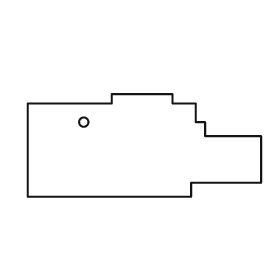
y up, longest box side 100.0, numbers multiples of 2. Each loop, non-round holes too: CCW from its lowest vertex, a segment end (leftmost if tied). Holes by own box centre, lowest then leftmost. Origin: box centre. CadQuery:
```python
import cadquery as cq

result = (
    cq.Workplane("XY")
    .moveTo(-50.0, -22.0)
    .lineTo(20.0, -22.0)
    .lineTo(20.0, -16.0)
    .lineTo(50.0, -16.0)
    .lineTo(50.0, 4.0)
    .lineTo(26.0, 4.0)
    .lineTo(26.0, 10.0)
    .lineTo(22.0, 10.0)
    .lineTo(22.0, 18.0)
    .lineTo(12.0, 18.0)
    .lineTo(12.0, 22.0)
    .lineTo(-14.0, 22.0)
    .lineTo(-14.0, 18.0)
    .lineTo(-50.0, 18.0)
    .close()
    .moveTo(-26.0, 10.0)
    .circle(2.0)
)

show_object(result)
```